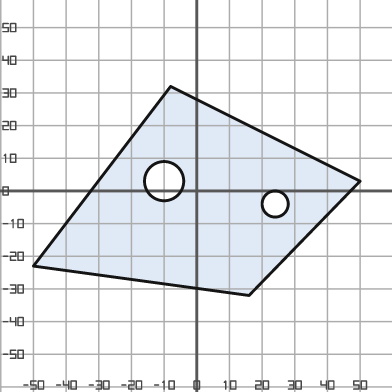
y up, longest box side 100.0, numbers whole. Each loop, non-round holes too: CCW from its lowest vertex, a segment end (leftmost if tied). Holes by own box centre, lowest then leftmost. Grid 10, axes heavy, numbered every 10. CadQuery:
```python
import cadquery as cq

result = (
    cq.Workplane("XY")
    .moveTo(16.0, -32.0)
    .lineTo(50.0, 3.0)
    .lineTo(-8.0, 32.0)
    .lineTo(-50.0, -23.0)
    .close()
    .moveTo(24.0, -4.0)
    .circle(4.0)
    .moveTo(-10.0, 3.0)
    .circle(6.0)
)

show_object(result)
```